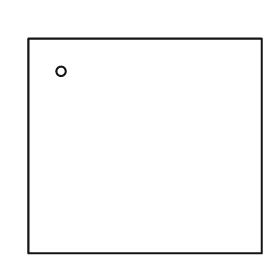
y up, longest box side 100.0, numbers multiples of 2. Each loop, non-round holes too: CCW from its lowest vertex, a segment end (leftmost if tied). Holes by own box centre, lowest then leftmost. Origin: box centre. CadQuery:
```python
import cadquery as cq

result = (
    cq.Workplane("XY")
    .moveTo(-50.0, -46.0)
    .lineTo(50.0, -46.0)
    .lineTo(50.0, 46.0)
    .lineTo(-50.0, 46.0)
    .close()
    .moveTo(-36.0, 32.0)
    .circle(2.0)
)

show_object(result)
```